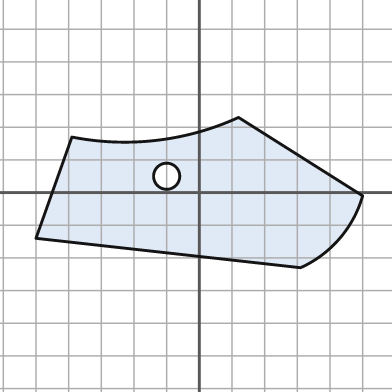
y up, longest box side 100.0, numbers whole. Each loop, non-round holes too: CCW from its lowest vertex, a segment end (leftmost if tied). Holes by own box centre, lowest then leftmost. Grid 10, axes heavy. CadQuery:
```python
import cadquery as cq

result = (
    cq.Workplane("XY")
    .moveTo(31.0, -23.0)
    .threePointArc((43.0, -14.0), (50.0, -1.0))
    .lineTo(12.0, 23.0)
    .threePointArc((-13.0, 16.0), (-39.0, 17.0))
    .lineTo(-50.0, -14.0)
    .close()
    .moveTo(-10.0, 5.0)
    .circle(4.0)
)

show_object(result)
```